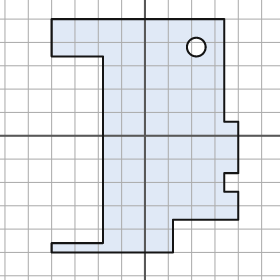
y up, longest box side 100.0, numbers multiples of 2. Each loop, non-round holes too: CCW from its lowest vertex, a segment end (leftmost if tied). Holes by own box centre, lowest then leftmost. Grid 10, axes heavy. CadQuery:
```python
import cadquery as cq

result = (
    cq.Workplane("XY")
    .moveTo(-40.0, -50.0)
    .lineTo(12.0, -50.0)
    .lineTo(12.0, -36.0)
    .lineTo(40.0, -36.0)
    .lineTo(40.0, -24.0)
    .lineTo(34.0, -24.0)
    .lineTo(34.0, -16.0)
    .lineTo(40.0, -16.0)
    .lineTo(40.0, 6.0)
    .lineTo(34.0, 6.0)
    .lineTo(34.0, 50.0)
    .lineTo(-40.0, 50.0)
    .lineTo(-40.0, 34.0)
    .lineTo(-18.0, 34.0)
    .lineTo(-18.0, -46.0)
    .lineTo(-40.0, -46.0)
    .close()
    .moveTo(22.0, 38.0)
    .circle(4.0)
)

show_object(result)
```